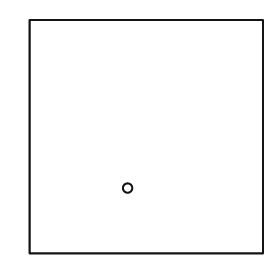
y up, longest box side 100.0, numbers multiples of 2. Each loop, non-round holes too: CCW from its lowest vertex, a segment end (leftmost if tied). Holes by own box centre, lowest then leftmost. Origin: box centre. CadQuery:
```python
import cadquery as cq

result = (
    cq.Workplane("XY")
    .moveTo(-50.0, -50.0)
    .lineTo(50.0, -50.0)
    .lineTo(50.0, 50.0)
    .lineTo(-50.0, 50.0)
    .close()
    .moveTo(-8.0, -22.0)
    .circle(2.0)
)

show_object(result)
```